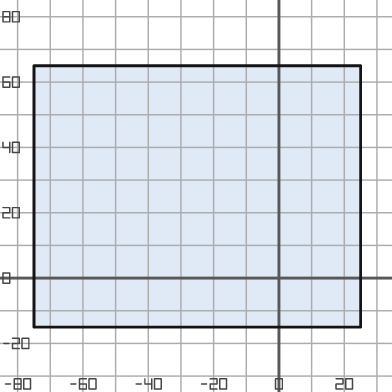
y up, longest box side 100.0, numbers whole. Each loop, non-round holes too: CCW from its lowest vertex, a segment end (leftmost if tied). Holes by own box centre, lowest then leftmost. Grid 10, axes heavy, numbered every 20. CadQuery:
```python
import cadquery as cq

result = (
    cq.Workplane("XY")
    .moveTo(-75.0, -15.0)
    .lineTo(25.0, -15.0)
    .lineTo(25.0, 65.0)
    .lineTo(-75.0, 65.0)
    .close()
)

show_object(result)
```